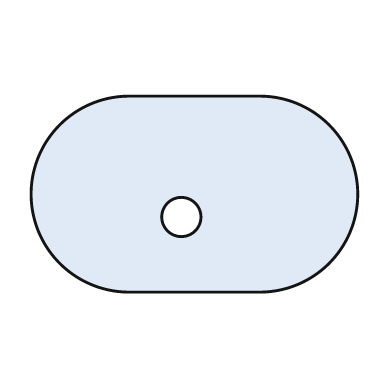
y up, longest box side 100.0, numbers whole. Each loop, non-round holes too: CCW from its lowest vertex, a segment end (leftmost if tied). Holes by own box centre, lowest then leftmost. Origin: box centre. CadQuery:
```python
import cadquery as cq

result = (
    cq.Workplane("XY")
    .moveTo(-20.0, -30.0)
    .lineTo(20.0, -30.0)
    .threePointArc((50.0, 0.0), (20.0, 30.0))
    .lineTo(-20.0, 30.0)
    .threePointArc((-50.0, 0.0), (-20.0, -30.0))
    .close()
    .moveTo(-4.0, -7.0)
    .circle(6.0)
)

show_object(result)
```